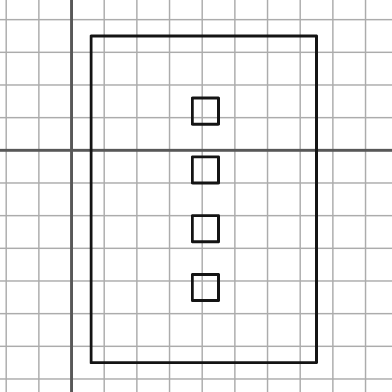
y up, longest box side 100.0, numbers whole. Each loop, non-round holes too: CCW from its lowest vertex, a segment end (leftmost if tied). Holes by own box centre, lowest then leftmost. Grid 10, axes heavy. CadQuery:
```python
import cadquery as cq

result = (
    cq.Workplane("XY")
    .moveTo(6.0, -65.0)
    .lineTo(75.0, -65.0)
    .lineTo(75.0, 35.0)
    .lineTo(6.0, 35.0)
    .close()
    .moveTo(37.0, -46.0)
    .lineTo(45.0, -46.0)
    .lineTo(45.0, -38.0)
    .lineTo(37.0, -38.0)
    .close()
    .moveTo(37.0, -28.0)
    .lineTo(45.0, -28.0)
    .lineTo(45.0, -20.0)
    .lineTo(37.0, -20.0)
    .close()
    .moveTo(37.0, -10.0)
    .lineTo(45.0, -10.0)
    .lineTo(45.0, -2.0)
    .lineTo(37.0, -2.0)
    .close()
    .moveTo(37.0, 8.0)
    .lineTo(45.0, 8.0)
    .lineTo(45.0, 16.0)
    .lineTo(37.0, 16.0)
    .close()
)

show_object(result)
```